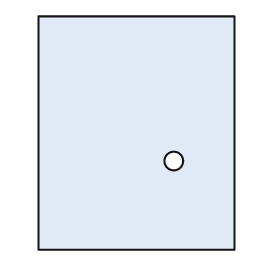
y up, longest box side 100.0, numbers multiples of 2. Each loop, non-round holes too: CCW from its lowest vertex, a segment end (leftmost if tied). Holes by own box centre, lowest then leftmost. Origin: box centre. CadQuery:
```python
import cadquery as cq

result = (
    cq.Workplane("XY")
    .moveTo(-42.0, -50.0)
    .lineTo(42.0, -50.0)
    .lineTo(42.0, 50.0)
    .lineTo(-42.0, 50.0)
    .close()
    .moveTo(16.0, -12.0)
    .circle(4.0)
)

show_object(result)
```